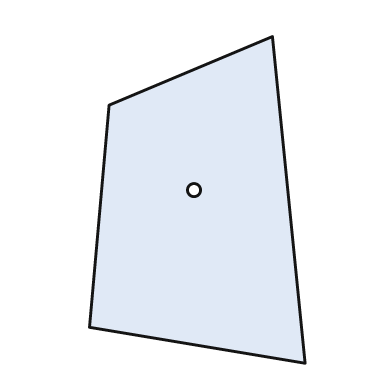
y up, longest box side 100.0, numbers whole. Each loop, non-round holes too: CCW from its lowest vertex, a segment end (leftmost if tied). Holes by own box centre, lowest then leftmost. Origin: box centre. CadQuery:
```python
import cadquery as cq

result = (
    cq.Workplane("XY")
    .moveTo(33.0, -50.0)
    .lineTo(23.0, 50.0)
    .lineTo(-27.0, 29.0)
    .lineTo(-33.0, -39.0)
    .close()
    .moveTo(-1.0, 3.0)
    .circle(2.0)
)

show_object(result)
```